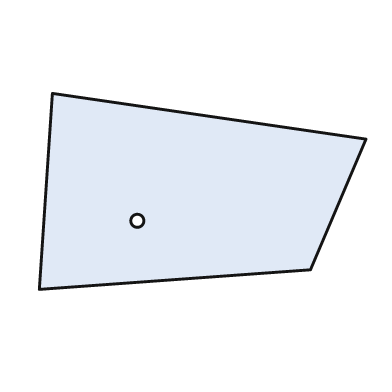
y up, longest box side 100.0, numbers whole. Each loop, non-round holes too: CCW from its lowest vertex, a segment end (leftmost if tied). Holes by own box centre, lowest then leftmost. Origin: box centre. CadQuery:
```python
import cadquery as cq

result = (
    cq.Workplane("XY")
    .moveTo(-50.0, -30.0)
    .lineTo(33.0, -24.0)
    .lineTo(50.0, 16.0)
    .lineTo(-46.0, 30.0)
    .close()
    .moveTo(-20.0, -9.0)
    .circle(2.0)
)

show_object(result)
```